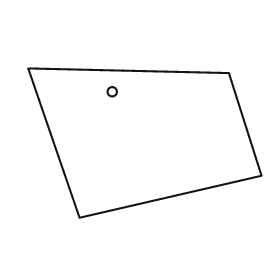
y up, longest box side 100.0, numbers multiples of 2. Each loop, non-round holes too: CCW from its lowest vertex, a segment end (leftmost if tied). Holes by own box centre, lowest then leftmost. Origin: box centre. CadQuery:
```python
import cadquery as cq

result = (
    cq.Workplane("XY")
    .moveTo(-28.0, -32.0)
    .lineTo(50.0, -14.0)
    .lineTo(36.0, 30.0)
    .lineTo(-50.0, 32.0)
    .close()
    .moveTo(-14.0, 22.0)
    .circle(2.0)
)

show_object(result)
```